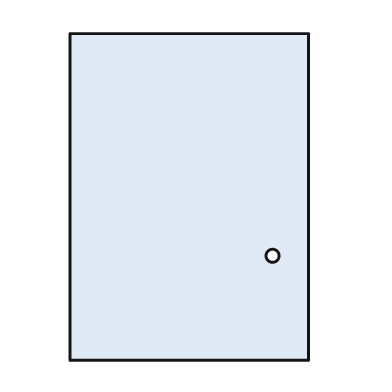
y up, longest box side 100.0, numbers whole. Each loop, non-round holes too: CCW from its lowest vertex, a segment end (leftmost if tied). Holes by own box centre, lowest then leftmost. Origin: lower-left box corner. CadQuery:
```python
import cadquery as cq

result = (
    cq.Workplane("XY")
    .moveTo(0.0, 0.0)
    .lineTo(73.0, 0.0)
    .lineTo(73.0, 100.0)
    .lineTo(0.0, 100.0)
    .close()
    .moveTo(62.0, 32.0)
    .circle(2.0)
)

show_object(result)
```